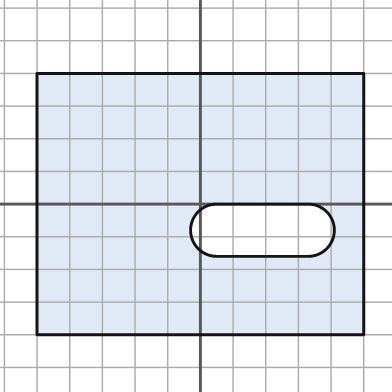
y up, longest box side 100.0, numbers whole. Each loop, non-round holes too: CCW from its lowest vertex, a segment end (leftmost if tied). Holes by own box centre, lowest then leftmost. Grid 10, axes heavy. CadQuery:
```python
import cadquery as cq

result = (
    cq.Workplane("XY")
    .moveTo(-50.0, -40.0)
    .lineTo(50.0, -40.0)
    .lineTo(50.0, 40.0)
    .lineTo(-50.0, 40.0)
    .close()
    .moveTo(5.0, -16.0)
    .lineTo(33.0, -16.0)
    .threePointArc((41.0, -8.0), (33.0, 0.0))
    .lineTo(5.0, 0.0)
    .threePointArc((-3.0, -8.0), (5.0, -16.0))
    .close()
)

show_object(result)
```